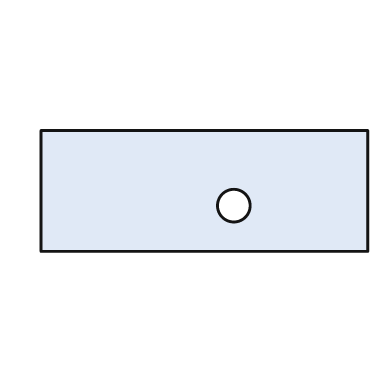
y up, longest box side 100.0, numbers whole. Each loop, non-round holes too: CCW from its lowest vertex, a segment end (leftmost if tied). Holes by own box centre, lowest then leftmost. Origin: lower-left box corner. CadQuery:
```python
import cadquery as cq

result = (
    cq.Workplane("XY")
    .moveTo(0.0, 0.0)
    .lineTo(100.0, 0.0)
    .lineTo(100.0, 37.0)
    .lineTo(0.0, 37.0)
    .close()
    .moveTo(59.0, 14.0)
    .circle(5.0)
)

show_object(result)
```